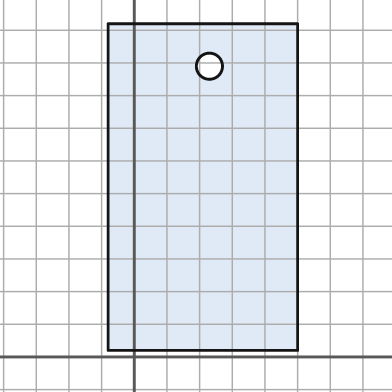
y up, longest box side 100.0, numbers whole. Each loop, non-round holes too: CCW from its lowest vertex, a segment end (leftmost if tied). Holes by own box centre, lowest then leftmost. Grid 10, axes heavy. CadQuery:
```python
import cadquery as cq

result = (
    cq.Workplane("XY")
    .moveTo(-8.0, 2.0)
    .lineTo(50.0, 2.0)
    .lineTo(50.0, 102.0)
    .lineTo(-8.0, 102.0)
    .close()
    .moveTo(23.0, 89.0)
    .circle(4.0)
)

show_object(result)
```